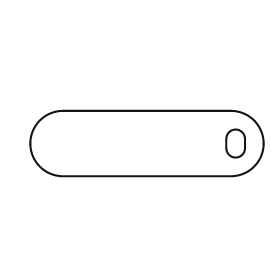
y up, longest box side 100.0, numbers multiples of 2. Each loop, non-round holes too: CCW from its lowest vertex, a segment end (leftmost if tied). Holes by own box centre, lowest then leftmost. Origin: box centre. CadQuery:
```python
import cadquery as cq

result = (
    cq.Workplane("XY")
    .moveTo(-36.0, -14.0)
    .lineTo(36.0, -14.0)
    .threePointArc((50.0, 0.0), (36.0, 14.0))
    .lineTo(-36.0, 14.0)
    .threePointArc((-50.0, 0.0), (-36.0, -14.0))
    .close()
    .moveTo(34.0, -2.0)
    .threePointArc((38.0, -6.0), (42.0, -2.0))
    .lineTo(42.0, 2.0)
    .threePointArc((38.0, 6.0), (34.0, 2.0))
    .close()
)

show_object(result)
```